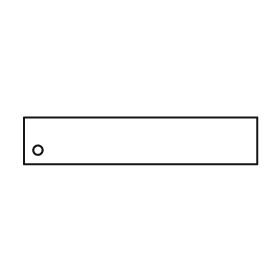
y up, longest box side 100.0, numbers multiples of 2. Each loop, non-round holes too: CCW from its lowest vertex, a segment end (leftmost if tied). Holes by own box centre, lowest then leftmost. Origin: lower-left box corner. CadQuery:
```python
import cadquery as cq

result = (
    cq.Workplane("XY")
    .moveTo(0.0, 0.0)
    .lineTo(100.0, 0.0)
    .lineTo(100.0, 20.0)
    .lineTo(0.0, 20.0)
    .close()
    .moveTo(6.0, 6.0)
    .circle(2.0)
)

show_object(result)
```